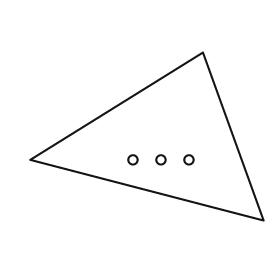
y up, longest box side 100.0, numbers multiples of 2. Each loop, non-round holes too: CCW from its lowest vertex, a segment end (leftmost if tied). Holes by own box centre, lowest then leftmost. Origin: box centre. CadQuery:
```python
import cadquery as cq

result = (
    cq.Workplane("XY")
    .moveTo(50.0, -36.0)
    .lineTo(24.0, 36.0)
    .lineTo(-50.0, -10.0)
    .close()
    .moveTo(-6.0, -10.0)
    .circle(2.0)
    .moveTo(6.0, -10.0)
    .circle(2.0)
    .moveTo(18.0, -10.0)
    .circle(2.0)
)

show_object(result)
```